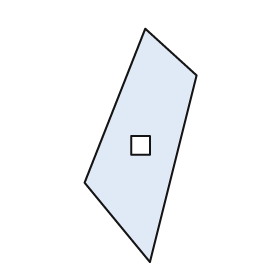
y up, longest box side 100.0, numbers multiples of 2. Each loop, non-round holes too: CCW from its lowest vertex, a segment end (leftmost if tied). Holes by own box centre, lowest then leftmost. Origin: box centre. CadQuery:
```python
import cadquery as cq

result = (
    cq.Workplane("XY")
    .moveTo(4.0, -50.0)
    .lineTo(24.0, 30.0)
    .lineTo(2.0, 50.0)
    .lineTo(-24.0, -16.0)
    .close()
    .moveTo(-4.0, -4.0)
    .lineTo(4.0, -4.0)
    .lineTo(4.0, 4.0)
    .lineTo(-4.0, 4.0)
    .close()
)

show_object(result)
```